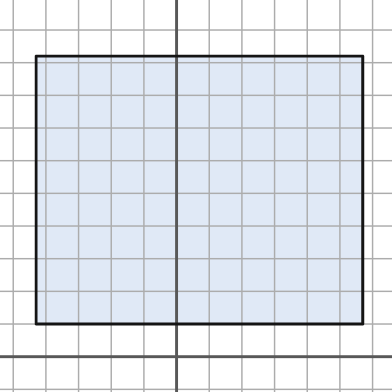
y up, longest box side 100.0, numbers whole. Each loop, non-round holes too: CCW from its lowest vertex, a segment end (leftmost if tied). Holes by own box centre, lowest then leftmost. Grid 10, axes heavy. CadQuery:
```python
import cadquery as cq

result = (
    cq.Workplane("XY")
    .moveTo(-43.0, 10.0)
    .lineTo(57.0, 10.0)
    .lineTo(57.0, 92.0)
    .lineTo(-43.0, 92.0)
    .close()
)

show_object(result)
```